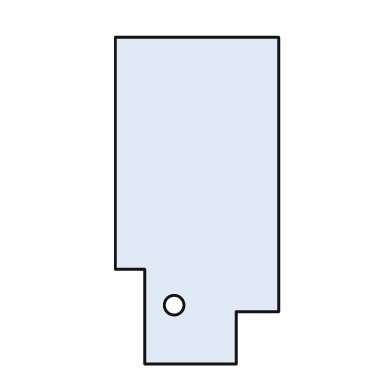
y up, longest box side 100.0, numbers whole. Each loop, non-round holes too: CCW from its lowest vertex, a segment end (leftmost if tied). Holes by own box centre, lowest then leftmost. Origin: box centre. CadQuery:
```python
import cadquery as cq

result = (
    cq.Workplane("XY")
    .moveTo(-16.0, -50.0)
    .lineTo(12.0, -50.0)
    .lineTo(12.0, -34.0)
    .lineTo(25.0, -34.0)
    .lineTo(25.0, 50.0)
    .lineTo(-25.0, 50.0)
    .lineTo(-25.0, -21.0)
    .lineTo(-16.0, -21.0)
    .close()
    .moveTo(-7.0, -32.0)
    .circle(3.0)
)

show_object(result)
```